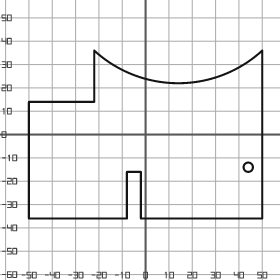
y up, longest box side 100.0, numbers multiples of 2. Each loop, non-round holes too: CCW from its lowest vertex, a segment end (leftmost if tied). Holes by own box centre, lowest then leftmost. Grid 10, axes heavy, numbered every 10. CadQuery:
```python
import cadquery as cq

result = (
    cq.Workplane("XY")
    .moveTo(-50.0, -36.0)
    .lineTo(-8.0, -36.0)
    .lineTo(-8.0, -16.0)
    .lineTo(-2.0, -16.0)
    .lineTo(-2.0, -36.0)
    .lineTo(50.0, -36.0)
    .lineTo(50.0, 36.0)
    .threePointArc((14.0, 22.0), (-22.0, 36.0))
    .lineTo(-22.0, 14.0)
    .lineTo(-50.0, 14.0)
    .close()
    .moveTo(44.0, -14.0)
    .circle(2.0)
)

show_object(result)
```